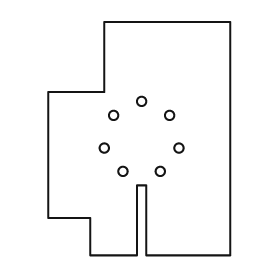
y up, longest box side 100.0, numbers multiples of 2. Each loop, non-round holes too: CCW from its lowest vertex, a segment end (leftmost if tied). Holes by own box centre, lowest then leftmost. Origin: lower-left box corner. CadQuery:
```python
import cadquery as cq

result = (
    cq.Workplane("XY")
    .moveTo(18.0, 0.0)
    .lineTo(38.0, 0.0)
    .lineTo(38.0, 30.0)
    .lineTo(42.0, 30.0)
    .lineTo(42.0, 0.0)
    .lineTo(78.0, 0.0)
    .lineTo(78.0, 100.0)
    .lineTo(24.0, 100.0)
    .lineTo(24.0, 70.0)
    .lineTo(0.0, 70.0)
    .lineTo(0.0, 16.0)
    .lineTo(18.0, 16.0)
    .close()
    .moveTo(32.0, 36.0)
    .circle(2.0)
    .moveTo(48.0, 36.0)
    .circle(2.0)
    .moveTo(24.0, 46.0)
    .circle(2.0)
    .moveTo(56.0, 46.0)
    .circle(2.0)
    .moveTo(28.0, 60.0)
    .circle(2.0)
    .moveTo(52.0, 60.0)
    .circle(2.0)
    .moveTo(40.0, 66.0)
    .circle(2.0)
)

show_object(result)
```